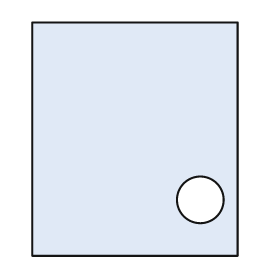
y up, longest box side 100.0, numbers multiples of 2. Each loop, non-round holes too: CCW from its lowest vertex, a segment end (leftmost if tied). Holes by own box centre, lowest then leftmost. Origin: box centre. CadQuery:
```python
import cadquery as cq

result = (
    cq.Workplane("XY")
    .moveTo(-44.0, -50.0)
    .lineTo(44.0, -50.0)
    .lineTo(44.0, 50.0)
    .lineTo(-44.0, 50.0)
    .close()
    .moveTo(28.0, -26.0)
    .circle(10.0)
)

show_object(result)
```